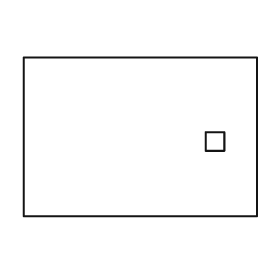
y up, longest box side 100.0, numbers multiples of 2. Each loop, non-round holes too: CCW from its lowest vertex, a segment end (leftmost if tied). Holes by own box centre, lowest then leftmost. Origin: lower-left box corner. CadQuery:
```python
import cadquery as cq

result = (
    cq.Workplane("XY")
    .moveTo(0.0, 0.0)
    .lineTo(100.0, 0.0)
    .lineTo(100.0, 68.0)
    .lineTo(0.0, 68.0)
    .close()
    .moveTo(78.0, 28.0)
    .lineTo(86.0, 28.0)
    .lineTo(86.0, 36.0)
    .lineTo(78.0, 36.0)
    .close()
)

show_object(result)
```